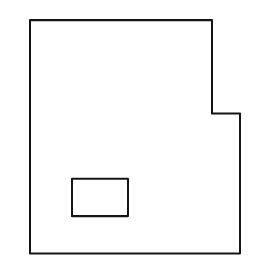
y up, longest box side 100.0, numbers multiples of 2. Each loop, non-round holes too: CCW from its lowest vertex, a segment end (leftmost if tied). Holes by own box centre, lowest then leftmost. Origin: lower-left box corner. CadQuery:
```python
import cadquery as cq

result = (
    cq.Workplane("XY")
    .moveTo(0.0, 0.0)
    .lineTo(90.0, 0.0)
    .lineTo(90.0, 60.0)
    .lineTo(78.0, 60.0)
    .lineTo(78.0, 100.0)
    .lineTo(0.0, 100.0)
    .close()
    .moveTo(18.0, 16.0)
    .lineTo(42.0, 16.0)
    .lineTo(42.0, 32.0)
    .lineTo(18.0, 32.0)
    .close()
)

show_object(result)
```